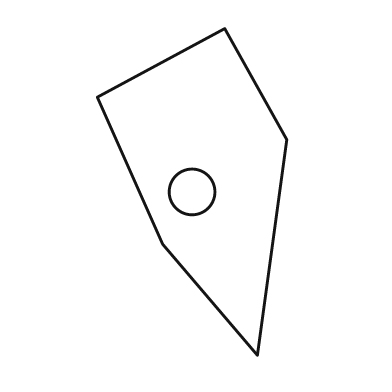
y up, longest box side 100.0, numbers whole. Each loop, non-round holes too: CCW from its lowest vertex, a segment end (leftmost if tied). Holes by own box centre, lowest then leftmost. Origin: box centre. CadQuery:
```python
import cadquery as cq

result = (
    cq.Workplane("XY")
    .moveTo(20.0, -50.0)
    .lineTo(29.0, 16.0)
    .lineTo(10.0, 50.0)
    .lineTo(-29.0, 29.0)
    .lineTo(-9.0, -16.0)
    .close()
    .moveTo(0.0, 0.0)
    .circle(7.0)
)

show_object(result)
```